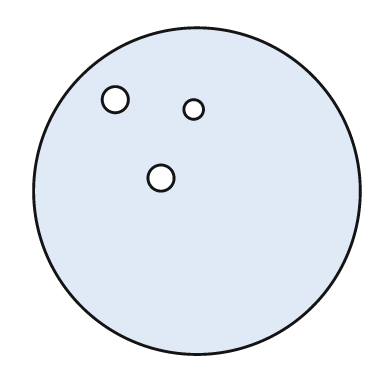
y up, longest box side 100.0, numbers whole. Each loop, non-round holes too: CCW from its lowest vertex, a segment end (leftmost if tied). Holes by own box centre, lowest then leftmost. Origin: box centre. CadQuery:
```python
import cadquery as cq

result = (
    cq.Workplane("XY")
    .moveTo(0.0, 0.0)
    .circle(50.0)
    .moveTo(-11.0, 4.0)
    .circle(4.0)
    .moveTo(-1.0, 25.0)
    .circle(3.0)
    .moveTo(-25.0, 28.0)
    .circle(4.0)
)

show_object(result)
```